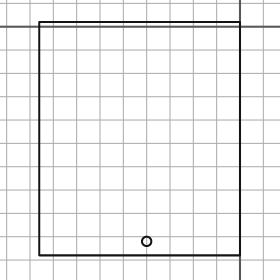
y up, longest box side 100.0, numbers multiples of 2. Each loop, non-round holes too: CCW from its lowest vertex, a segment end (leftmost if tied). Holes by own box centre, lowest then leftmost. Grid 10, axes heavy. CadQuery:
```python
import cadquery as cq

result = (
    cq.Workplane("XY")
    .moveTo(-86.0, -98.0)
    .lineTo(0.0, -98.0)
    .lineTo(0.0, 2.0)
    .lineTo(-86.0, 2.0)
    .close()
    .moveTo(-40.0, -92.0)
    .circle(2.0)
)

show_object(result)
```